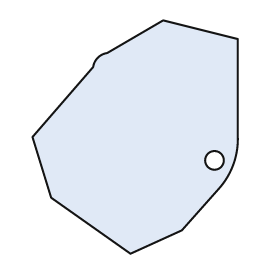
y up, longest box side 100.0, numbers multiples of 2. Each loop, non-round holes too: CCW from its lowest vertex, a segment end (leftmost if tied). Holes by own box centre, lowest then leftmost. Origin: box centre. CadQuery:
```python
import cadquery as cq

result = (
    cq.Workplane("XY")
    .moveTo(-2.0, -50.0)
    .lineTo(20.0, -40.0)
    .lineTo(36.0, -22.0)
    .threePointArc((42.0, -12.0), (44.0, 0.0))
    .lineTo(44.0, 42.0)
    .lineTo(12.0, 50.0)
    .lineTo(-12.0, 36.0)
    .threePointArc((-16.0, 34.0), (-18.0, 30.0))
    .lineTo(-44.0, 0.0)
    .lineTo(-36.0, -26.0)
    .close()
    .moveTo(34.0, -10.0)
    .circle(4.0)
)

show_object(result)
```